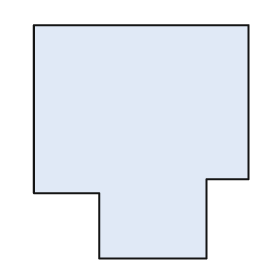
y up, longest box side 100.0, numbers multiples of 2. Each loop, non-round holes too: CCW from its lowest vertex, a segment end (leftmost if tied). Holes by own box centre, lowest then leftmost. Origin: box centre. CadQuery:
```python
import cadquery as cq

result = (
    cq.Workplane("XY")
    .moveTo(-18.0, -50.0)
    .lineTo(28.0, -50.0)
    .lineTo(28.0, -16.0)
    .lineTo(46.0, -16.0)
    .lineTo(46.0, 50.0)
    .lineTo(-46.0, 50.0)
    .lineTo(-46.0, -22.0)
    .lineTo(-18.0, -22.0)
    .close()
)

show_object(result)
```